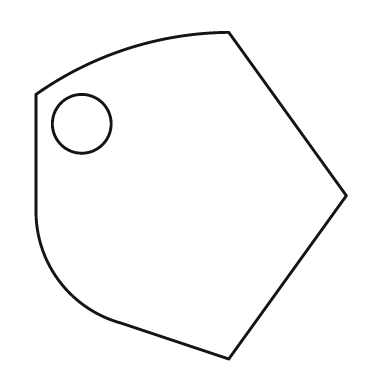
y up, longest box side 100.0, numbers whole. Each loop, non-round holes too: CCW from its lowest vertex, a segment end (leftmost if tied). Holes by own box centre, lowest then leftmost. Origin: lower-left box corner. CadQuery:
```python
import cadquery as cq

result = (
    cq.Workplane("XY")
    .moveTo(59.0, 0.0)
    .lineTo(95.0, 50.0)
    .lineTo(59.0, 100.0)
    .threePointArc((28.0, 95.0), (0.0, 81.0))
    .lineTo(0.0, 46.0)
    .threePointArc((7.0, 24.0), (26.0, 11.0))
    .close()
    .moveTo(14.0, 72.0)
    .circle(9.0)
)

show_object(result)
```